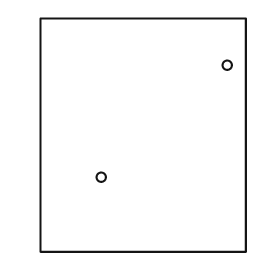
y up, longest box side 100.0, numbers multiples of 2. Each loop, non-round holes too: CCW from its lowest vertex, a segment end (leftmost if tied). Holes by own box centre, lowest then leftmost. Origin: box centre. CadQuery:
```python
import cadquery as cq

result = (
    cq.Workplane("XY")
    .moveTo(-44.0, -50.0)
    .lineTo(44.0, -50.0)
    .lineTo(44.0, 50.0)
    .lineTo(-44.0, 50.0)
    .close()
    .moveTo(-18.0, -18.0)
    .circle(2.0)
    .moveTo(36.0, 30.0)
    .circle(2.0)
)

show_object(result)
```